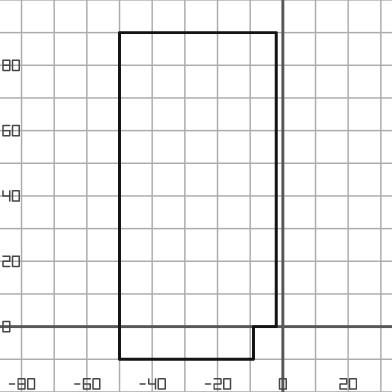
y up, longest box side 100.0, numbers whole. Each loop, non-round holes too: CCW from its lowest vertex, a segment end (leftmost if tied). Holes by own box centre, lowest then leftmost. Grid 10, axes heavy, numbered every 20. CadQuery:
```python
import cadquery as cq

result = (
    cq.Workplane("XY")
    .moveTo(-50.0, -10.0)
    .lineTo(-9.0, -10.0)
    .lineTo(-9.0, 0.0)
    .lineTo(-2.0, 0.0)
    .lineTo(-2.0, 90.0)
    .lineTo(-50.0, 90.0)
    .close()
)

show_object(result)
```